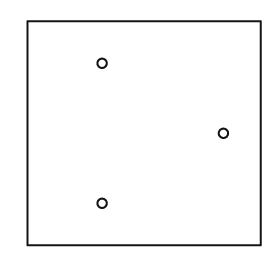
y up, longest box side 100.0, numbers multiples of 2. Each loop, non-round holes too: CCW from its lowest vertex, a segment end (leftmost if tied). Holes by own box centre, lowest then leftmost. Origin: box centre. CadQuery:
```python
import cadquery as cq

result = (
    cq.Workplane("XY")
    .moveTo(-50.0, -48.0)
    .lineTo(50.0, -48.0)
    .lineTo(50.0, 48.0)
    .lineTo(-50.0, 48.0)
    .close()
    .moveTo(-18.0, -30.0)
    .circle(2.0)
    .moveTo(34.0, 0.0)
    .circle(2.0)
    .moveTo(-18.0, 30.0)
    .circle(2.0)
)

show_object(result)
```